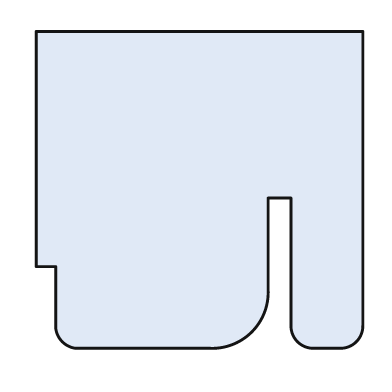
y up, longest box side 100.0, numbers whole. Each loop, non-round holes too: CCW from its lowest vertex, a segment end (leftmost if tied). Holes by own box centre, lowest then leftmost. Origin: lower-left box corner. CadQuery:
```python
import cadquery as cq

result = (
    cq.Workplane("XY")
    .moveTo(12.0, 0.0)
    .lineTo(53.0, 0.0)
    .threePointArc((66.0, 5.0), (71.0, 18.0))
    .lineTo(71.0, 46.0)
    .lineTo(78.0, 46.0)
    .lineTo(78.0, 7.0)
    .threePointArc((80.0, 2.0), (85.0, 0.0))
    .lineTo(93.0, 0.0)
    .threePointArc((98.0, 2.0), (100.0, 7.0))
    .lineTo(100.0, 97.0)
    .lineTo(0.0, 97.0)
    .lineTo(0.0, 25.0)
    .lineTo(6.0, 25.0)
    .lineTo(6.0, 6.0)
    .threePointArc((8.0, 2.0), (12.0, 0.0))
    .close()
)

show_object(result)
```